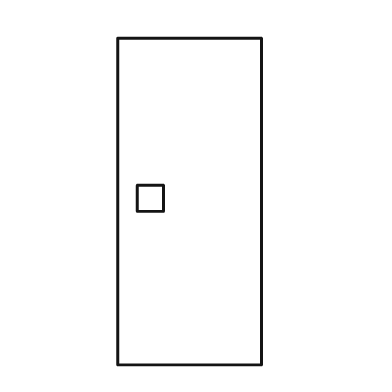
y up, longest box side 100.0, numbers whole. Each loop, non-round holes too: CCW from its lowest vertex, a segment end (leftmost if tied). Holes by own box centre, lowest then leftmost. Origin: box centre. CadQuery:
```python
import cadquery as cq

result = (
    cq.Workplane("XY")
    .moveTo(-22.0, -50.0)
    .lineTo(22.0, -50.0)
    .lineTo(22.0, 50.0)
    .lineTo(-22.0, 50.0)
    .close()
    .moveTo(-16.0, -3.0)
    .lineTo(-8.0, -3.0)
    .lineTo(-8.0, 5.0)
    .lineTo(-16.0, 5.0)
    .close()
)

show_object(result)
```